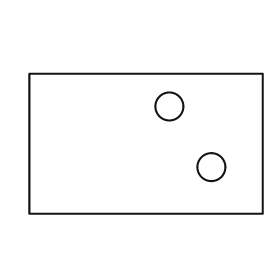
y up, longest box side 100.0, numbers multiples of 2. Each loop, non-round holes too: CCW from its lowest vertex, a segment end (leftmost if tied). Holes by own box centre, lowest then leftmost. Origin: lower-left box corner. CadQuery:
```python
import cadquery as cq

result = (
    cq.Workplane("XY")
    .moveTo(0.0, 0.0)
    .lineTo(100.0, 0.0)
    .lineTo(100.0, 60.0)
    .lineTo(0.0, 60.0)
    .close()
    .moveTo(78.0, 20.0)
    .circle(6.0)
    .moveTo(60.0, 46.0)
    .circle(6.0)
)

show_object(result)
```